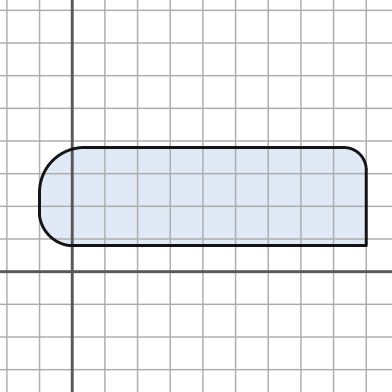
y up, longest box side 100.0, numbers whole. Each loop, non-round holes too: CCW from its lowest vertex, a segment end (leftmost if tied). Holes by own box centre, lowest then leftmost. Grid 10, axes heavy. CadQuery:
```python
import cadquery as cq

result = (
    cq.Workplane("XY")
    .moveTo(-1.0, 8.0)
    .lineTo(90.0, 8.0)
    .lineTo(90.0, 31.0)
    .threePointArc((88.0, 36.0), (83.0, 38.0))
    .lineTo(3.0, 38.0)
    .threePointArc((-6.0, 34.0), (-10.0, 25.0))
    .lineTo(-10.0, 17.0)
    .threePointArc((-7.0, 11.0), (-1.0, 8.0))
    .close()
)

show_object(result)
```